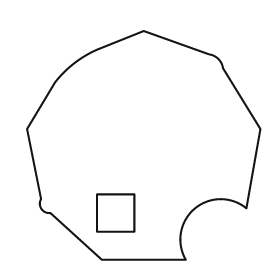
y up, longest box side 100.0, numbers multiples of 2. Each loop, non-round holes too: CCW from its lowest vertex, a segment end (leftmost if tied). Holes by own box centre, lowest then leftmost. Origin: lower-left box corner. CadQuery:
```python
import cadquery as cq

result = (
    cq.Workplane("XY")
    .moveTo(32.0, 0.0)
    .lineTo(68.0, 0.0)
    .threePointArc((72.0, 22.0), (94.0, 22.0))
    .lineTo(100.0, 56.0)
    .lineTo(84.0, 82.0)
    .threePointArc((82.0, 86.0), (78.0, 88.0))
    .lineTo(50.0, 98.0)
    .lineTo(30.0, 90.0)
    .threePointArc((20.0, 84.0), (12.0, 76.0))
    .lineTo(0.0, 56.0)
    .lineTo(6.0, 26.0)
    .threePointArc((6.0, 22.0), (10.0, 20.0))
    .close()
    .moveTo(30.0, 12.0)
    .lineTo(46.0, 12.0)
    .lineTo(46.0, 28.0)
    .lineTo(30.0, 28.0)
    .close()
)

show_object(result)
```